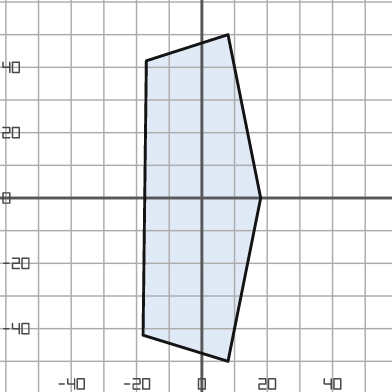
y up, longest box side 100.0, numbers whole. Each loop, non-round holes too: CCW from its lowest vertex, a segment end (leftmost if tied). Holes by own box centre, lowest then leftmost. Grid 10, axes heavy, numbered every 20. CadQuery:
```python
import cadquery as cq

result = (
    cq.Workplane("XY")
    .moveTo(8.0, -50.0)
    .lineTo(18.0, 0.0)
    .lineTo(8.0, 50.0)
    .lineTo(-17.0, 42.0)
    .lineTo(-18.0, -42.0)
    .close()
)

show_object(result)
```